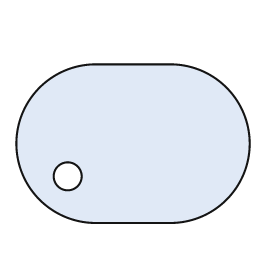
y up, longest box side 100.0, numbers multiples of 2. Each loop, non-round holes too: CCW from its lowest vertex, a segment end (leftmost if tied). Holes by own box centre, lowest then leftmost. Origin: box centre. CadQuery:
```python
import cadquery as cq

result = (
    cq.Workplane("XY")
    .moveTo(-16.0, -34.0)
    .lineTo(16.0, -34.0)
    .threePointArc((50.0, 0.0), (16.0, 34.0))
    .lineTo(-16.0, 34.0)
    .threePointArc((-50.0, 0.0), (-16.0, -34.0))
    .close()
    .moveTo(-28.0, -14.0)
    .circle(6.0)
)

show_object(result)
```